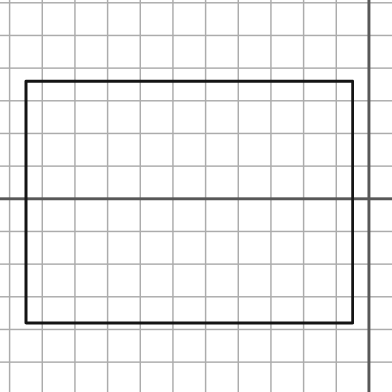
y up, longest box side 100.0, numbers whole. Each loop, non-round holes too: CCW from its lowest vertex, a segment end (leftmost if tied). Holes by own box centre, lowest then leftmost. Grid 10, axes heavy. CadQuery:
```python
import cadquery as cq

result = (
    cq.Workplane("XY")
    .moveTo(-105.0, -38.0)
    .lineTo(-5.0, -38.0)
    .lineTo(-5.0, 36.0)
    .lineTo(-105.0, 36.0)
    .close()
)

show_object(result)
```